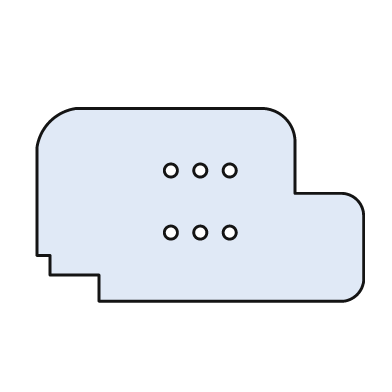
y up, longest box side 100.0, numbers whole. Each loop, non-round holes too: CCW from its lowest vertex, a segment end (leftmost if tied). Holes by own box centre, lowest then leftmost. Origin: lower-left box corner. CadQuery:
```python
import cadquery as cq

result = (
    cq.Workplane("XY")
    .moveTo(19.0, 0.0)
    .lineTo(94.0, 0.0)
    .threePointArc((98.0, 2.0), (100.0, 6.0))
    .lineTo(100.0, 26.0)
    .threePointArc((98.0, 31.0), (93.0, 33.0))
    .lineTo(79.0, 33.0)
    .lineTo(79.0, 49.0)
    .threePointArc((76.0, 56.0), (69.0, 59.0))
    .lineTo(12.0, 59.0)
    .threePointArc((4.0, 55.0), (0.0, 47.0))
    .lineTo(0.0, 14.0)
    .lineTo(4.0, 14.0)
    .lineTo(4.0, 8.0)
    .lineTo(19.0, 8.0)
    .close()
    .moveTo(41.0, 21.0)
    .circle(2.0)
    .moveTo(50.0, 21.0)
    .circle(2.0)
    .moveTo(59.0, 21.0)
    .circle(2.0)
    .moveTo(41.0, 40.0)
    .circle(2.0)
    .moveTo(50.0, 40.0)
    .circle(2.0)
    .moveTo(59.0, 40.0)
    .circle(2.0)
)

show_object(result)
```